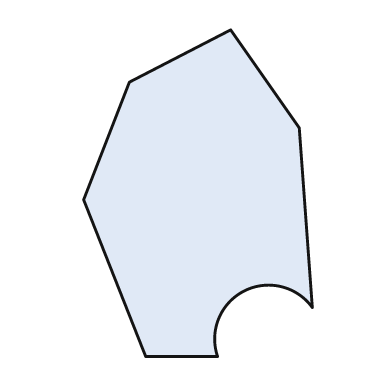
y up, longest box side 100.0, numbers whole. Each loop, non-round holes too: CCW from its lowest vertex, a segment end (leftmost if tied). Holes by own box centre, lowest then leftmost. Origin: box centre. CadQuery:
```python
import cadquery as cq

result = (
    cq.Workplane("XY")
    .moveTo(-16.0, -50.0)
    .lineTo(6.0, -50.0)
    .threePointArc((14.0, -30.0), (35.0, -35.0))
    .lineTo(31.0, 20.0)
    .lineTo(10.0, 50.0)
    .lineTo(-21.0, 34.0)
    .lineTo(-35.0, -2.0)
    .close()
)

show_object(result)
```